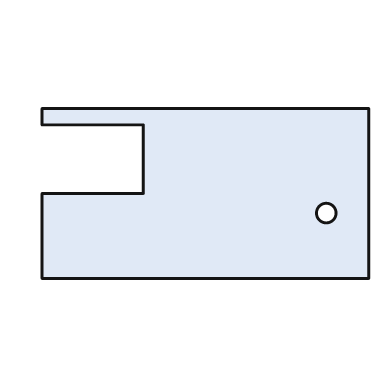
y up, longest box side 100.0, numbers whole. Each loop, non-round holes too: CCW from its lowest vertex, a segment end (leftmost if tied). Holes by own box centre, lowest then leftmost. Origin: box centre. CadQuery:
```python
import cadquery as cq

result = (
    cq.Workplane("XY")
    .moveTo(-50.0, -26.0)
    .lineTo(50.0, -26.0)
    .lineTo(50.0, 26.0)
    .lineTo(-50.0, 26.0)
    .lineTo(-50.0, 21.0)
    .lineTo(-19.0, 21.0)
    .lineTo(-19.0, 0.0)
    .lineTo(-50.0, 0.0)
    .close()
    .moveTo(37.0, -6.0)
    .circle(3.0)
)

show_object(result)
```